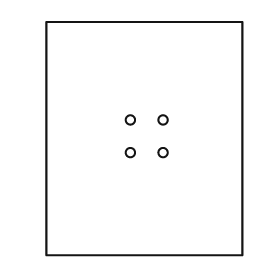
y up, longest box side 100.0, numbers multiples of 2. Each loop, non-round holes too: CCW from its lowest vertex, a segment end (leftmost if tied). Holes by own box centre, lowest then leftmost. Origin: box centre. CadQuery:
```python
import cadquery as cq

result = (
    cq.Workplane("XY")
    .moveTo(-42.0, -50.0)
    .lineTo(42.0, -50.0)
    .lineTo(42.0, 50.0)
    .lineTo(-42.0, 50.0)
    .close()
    .moveTo(-6.0, -6.0)
    .circle(2.0)
    .moveTo(8.0, -6.0)
    .circle(2.0)
    .moveTo(-6.0, 8.0)
    .circle(2.0)
    .moveTo(8.0, 8.0)
    .circle(2.0)
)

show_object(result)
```